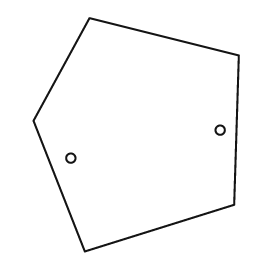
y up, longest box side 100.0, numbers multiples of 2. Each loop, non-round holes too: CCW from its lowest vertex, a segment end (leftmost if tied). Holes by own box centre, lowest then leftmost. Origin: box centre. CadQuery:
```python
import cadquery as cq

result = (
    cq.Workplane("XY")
    .moveTo(-22.0, -50.0)
    .lineTo(42.0, -30.0)
    .lineTo(44.0, 34.0)
    .lineTo(-20.0, 50.0)
    .lineTo(-44.0, 6.0)
    .close()
    .moveTo(-28.0, -10.0)
    .circle(2.0)
    .moveTo(36.0, 2.0)
    .circle(2.0)
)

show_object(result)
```